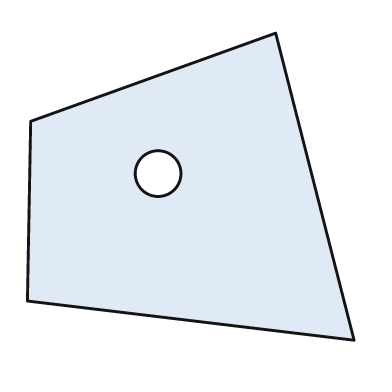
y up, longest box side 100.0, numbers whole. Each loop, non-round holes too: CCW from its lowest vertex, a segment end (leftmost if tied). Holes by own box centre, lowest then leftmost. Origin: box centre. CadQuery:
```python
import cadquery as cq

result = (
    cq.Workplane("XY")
    .moveTo(50.0, -47.0)
    .lineTo(26.0, 47.0)
    .lineTo(-49.0, 20.0)
    .lineTo(-50.0, -35.0)
    .close()
    .moveTo(-10.0, 4.0)
    .circle(7.0)
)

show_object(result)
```